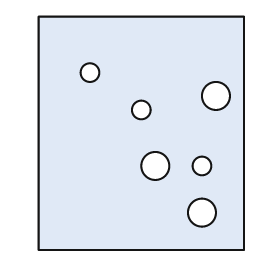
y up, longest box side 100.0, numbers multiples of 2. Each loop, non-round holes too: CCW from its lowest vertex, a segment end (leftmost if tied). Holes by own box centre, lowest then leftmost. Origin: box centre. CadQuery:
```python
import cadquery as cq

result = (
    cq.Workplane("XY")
    .moveTo(-44.0, -50.0)
    .lineTo(44.0, -50.0)
    .lineTo(44.0, 50.0)
    .lineTo(-44.0, 50.0)
    .close()
    .moveTo(26.0, -34.0)
    .circle(6.0)
    .moveTo(6.0, -14.0)
    .circle(6.0)
    .moveTo(26.0, -14.0)
    .circle(4.0)
    .moveTo(0.0, 10.0)
    .circle(4.0)
    .moveTo(32.0, 16.0)
    .circle(6.0)
    .moveTo(-22.0, 26.0)
    .circle(4.0)
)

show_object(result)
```